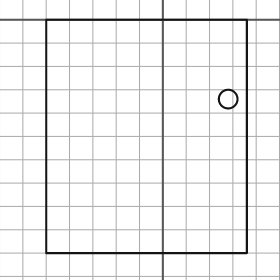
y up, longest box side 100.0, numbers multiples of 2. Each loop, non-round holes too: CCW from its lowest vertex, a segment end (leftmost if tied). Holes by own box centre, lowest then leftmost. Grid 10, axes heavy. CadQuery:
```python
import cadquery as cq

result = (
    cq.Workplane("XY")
    .moveTo(-50.0, -100.0)
    .lineTo(36.0, -100.0)
    .lineTo(36.0, 0.0)
    .lineTo(-50.0, 0.0)
    .close()
    .moveTo(28.0, -34.0)
    .circle(4.0)
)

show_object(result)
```